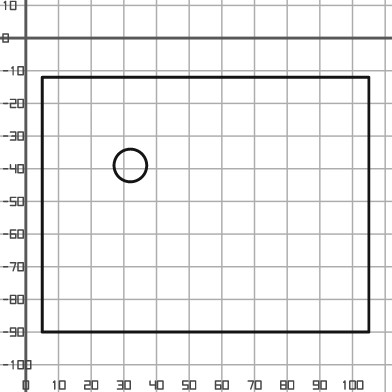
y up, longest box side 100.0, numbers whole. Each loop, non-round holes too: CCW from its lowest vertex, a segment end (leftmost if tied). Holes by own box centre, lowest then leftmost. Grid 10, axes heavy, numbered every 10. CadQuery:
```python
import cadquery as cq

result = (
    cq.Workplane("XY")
    .moveTo(5.0, -90.0)
    .lineTo(105.0, -90.0)
    .lineTo(105.0, -12.0)
    .lineTo(5.0, -12.0)
    .close()
    .moveTo(32.0, -39.0)
    .circle(5.0)
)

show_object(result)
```